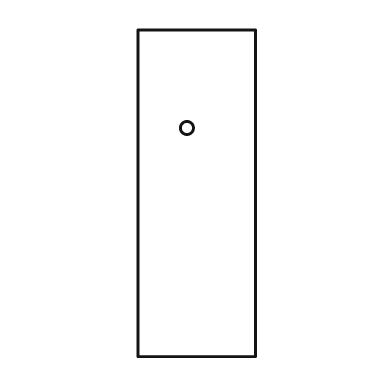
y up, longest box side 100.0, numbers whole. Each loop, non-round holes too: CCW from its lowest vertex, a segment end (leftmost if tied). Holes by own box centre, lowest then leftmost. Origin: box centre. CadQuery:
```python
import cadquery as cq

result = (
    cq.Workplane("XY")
    .moveTo(-18.0, -50.0)
    .lineTo(18.0, -50.0)
    .lineTo(18.0, 50.0)
    .lineTo(-18.0, 50.0)
    .close()
    .moveTo(-3.0, 20.0)
    .circle(2.0)
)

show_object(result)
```